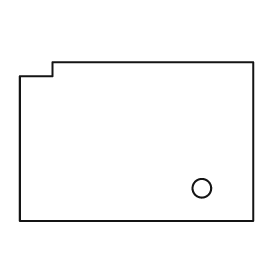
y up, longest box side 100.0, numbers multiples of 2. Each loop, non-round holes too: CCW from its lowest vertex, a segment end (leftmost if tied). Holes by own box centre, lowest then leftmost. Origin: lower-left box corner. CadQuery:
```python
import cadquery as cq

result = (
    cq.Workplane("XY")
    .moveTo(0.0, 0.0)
    .lineTo(100.0, 0.0)
    .lineTo(100.0, 68.0)
    .lineTo(14.0, 68.0)
    .lineTo(14.0, 62.0)
    .lineTo(0.0, 62.0)
    .close()
    .moveTo(78.0, 14.0)
    .circle(4.0)
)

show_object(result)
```